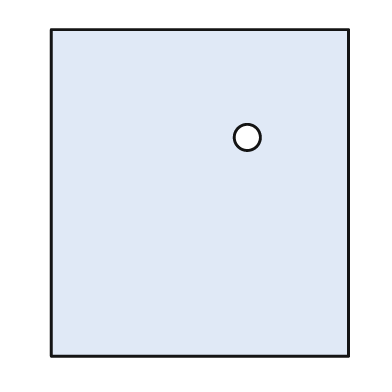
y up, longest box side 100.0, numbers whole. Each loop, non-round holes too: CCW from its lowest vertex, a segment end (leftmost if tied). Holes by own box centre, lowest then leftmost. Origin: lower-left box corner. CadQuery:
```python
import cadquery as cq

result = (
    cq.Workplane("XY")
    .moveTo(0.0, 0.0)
    .lineTo(91.0, 0.0)
    .lineTo(91.0, 100.0)
    .lineTo(0.0, 100.0)
    .close()
    .moveTo(60.0, 67.0)
    .circle(4.0)
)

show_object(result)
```